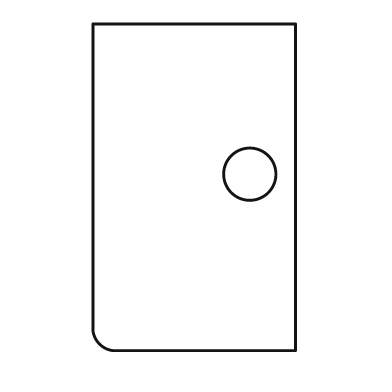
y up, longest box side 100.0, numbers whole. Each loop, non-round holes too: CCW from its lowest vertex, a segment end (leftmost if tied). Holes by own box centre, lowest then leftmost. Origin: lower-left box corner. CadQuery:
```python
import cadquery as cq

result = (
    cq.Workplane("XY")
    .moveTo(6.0, 0.0)
    .lineTo(62.0, 0.0)
    .lineTo(62.0, 100.0)
    .lineTo(0.0, 100.0)
    .lineTo(0.0, 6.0)
    .threePointArc((2.0, 2.0), (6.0, 0.0))
    .close()
    .moveTo(48.0, 54.0)
    .circle(8.0)
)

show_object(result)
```